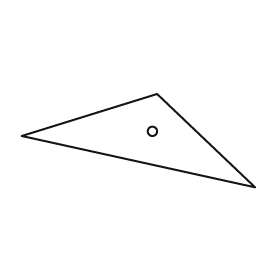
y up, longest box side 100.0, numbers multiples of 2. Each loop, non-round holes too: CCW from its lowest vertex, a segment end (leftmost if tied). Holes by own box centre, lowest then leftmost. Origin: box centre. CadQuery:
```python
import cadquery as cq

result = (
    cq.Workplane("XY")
    .moveTo(50.0, -20.0)
    .lineTo(8.0, 20.0)
    .lineTo(-50.0, 2.0)
    .close()
    .moveTo(6.0, 4.0)
    .circle(2.0)
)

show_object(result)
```